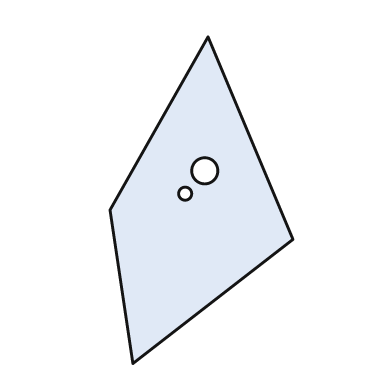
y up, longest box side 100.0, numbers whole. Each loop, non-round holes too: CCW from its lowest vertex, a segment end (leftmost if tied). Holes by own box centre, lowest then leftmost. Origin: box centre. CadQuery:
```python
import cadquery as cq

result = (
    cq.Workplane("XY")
    .moveTo(-21.0, -50.0)
    .lineTo(28.0, -12.0)
    .lineTo(2.0, 50.0)
    .lineTo(-28.0, -3.0)
    .close()
    .moveTo(-5.0, 2.0)
    .circle(2.0)
    .moveTo(1.0, 9.0)
    .circle(4.0)
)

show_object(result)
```